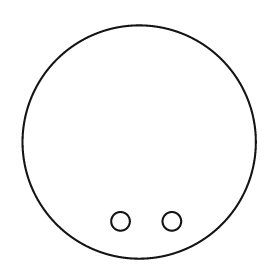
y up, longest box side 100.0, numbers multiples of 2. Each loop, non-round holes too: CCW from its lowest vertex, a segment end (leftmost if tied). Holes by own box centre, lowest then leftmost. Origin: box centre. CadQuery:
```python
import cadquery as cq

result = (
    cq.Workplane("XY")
    .moveTo(0.0, 0.0)
    .circle(50.0)
    .moveTo(-8.0, -34.0)
    .circle(4.0)
    .moveTo(14.0, -34.0)
    .circle(4.0)
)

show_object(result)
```